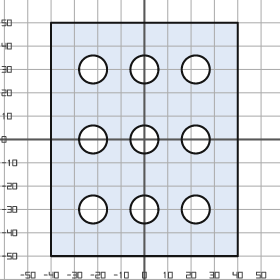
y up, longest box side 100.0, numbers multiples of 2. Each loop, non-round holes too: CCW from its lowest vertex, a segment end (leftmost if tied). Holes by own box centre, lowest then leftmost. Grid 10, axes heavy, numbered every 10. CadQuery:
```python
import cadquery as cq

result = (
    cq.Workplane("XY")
    .moveTo(-40.0, -50.0)
    .lineTo(40.0, -50.0)
    .lineTo(40.0, 50.0)
    .lineTo(-40.0, 50.0)
    .close()
    .moveTo(-22.0, -30.0)
    .circle(6.0)
    .moveTo(0.0, -30.0)
    .circle(6.0)
    .moveTo(22.0, -30.0)
    .circle(6.0)
    .moveTo(-22.0, 0.0)
    .circle(6.0)
    .moveTo(0.0, 0.0)
    .circle(6.0)
    .moveTo(22.0, 0.0)
    .circle(6.0)
    .moveTo(-22.0, 30.0)
    .circle(6.0)
    .moveTo(0.0, 30.0)
    .circle(6.0)
    .moveTo(22.0, 30.0)
    .circle(6.0)
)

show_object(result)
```